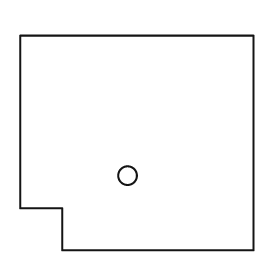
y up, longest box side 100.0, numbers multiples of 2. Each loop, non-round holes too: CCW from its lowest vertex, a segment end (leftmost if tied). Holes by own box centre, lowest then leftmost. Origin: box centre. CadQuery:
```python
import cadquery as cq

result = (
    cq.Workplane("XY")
    .moveTo(-32.0, -46.0)
    .lineTo(50.0, -46.0)
    .lineTo(50.0, 46.0)
    .lineTo(-50.0, 46.0)
    .lineTo(-50.0, -28.0)
    .lineTo(-32.0, -28.0)
    .close()
    .moveTo(-4.0, -14.0)
    .circle(4.0)
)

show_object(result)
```